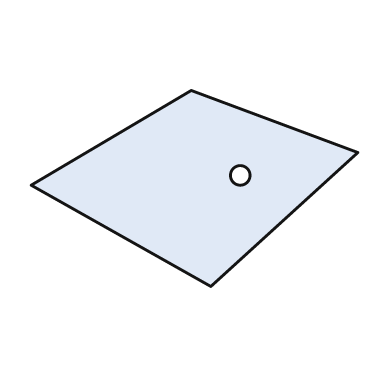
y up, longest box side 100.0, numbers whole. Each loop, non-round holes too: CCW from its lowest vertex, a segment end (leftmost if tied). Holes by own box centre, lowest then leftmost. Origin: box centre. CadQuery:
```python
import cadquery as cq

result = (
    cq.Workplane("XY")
    .moveTo(5.0, -30.0)
    .lineTo(50.0, 11.0)
    .lineTo(-1.0, 30.0)
    .lineTo(-50.0, 1.0)
    .close()
    .moveTo(14.0, 4.0)
    .circle(3.0)
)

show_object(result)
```